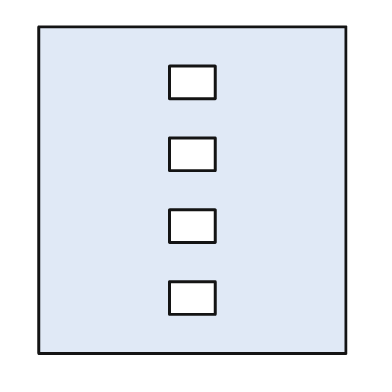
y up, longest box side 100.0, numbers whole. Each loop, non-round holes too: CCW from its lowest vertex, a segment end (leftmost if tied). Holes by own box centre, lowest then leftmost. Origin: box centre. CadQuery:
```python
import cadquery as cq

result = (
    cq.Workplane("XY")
    .moveTo(-47.0, -50.0)
    .lineTo(47.0, -50.0)
    .lineTo(47.0, 50.0)
    .lineTo(-47.0, 50.0)
    .close()
    .moveTo(-7.0, -38.0)
    .lineTo(7.0, -38.0)
    .lineTo(7.0, -28.0)
    .lineTo(-7.0, -28.0)
    .close()
    .moveTo(-7.0, -16.0)
    .lineTo(7.0, -16.0)
    .lineTo(7.0, -6.0)
    .lineTo(-7.0, -6.0)
    .close()
    .moveTo(-7.0, 6.0)
    .lineTo(7.0, 6.0)
    .lineTo(7.0, 16.0)
    .lineTo(-7.0, 16.0)
    .close()
    .moveTo(-7.0, 28.0)
    .lineTo(7.0, 28.0)
    .lineTo(7.0, 38.0)
    .lineTo(-7.0, 38.0)
    .close()
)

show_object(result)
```